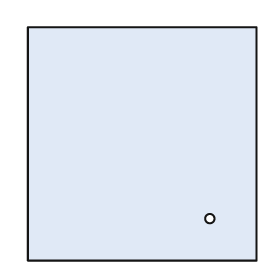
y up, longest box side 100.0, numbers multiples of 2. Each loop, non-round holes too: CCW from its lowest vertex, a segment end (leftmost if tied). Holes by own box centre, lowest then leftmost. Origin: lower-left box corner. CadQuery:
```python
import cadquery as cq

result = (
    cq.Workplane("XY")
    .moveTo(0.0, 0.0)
    .lineTo(98.0, 0.0)
    .lineTo(98.0, 100.0)
    .lineTo(0.0, 100.0)
    .close()
    .moveTo(78.0, 18.0)
    .circle(2.0)
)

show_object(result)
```